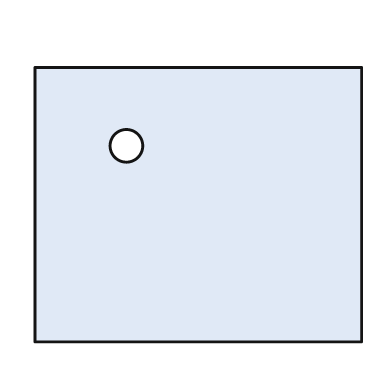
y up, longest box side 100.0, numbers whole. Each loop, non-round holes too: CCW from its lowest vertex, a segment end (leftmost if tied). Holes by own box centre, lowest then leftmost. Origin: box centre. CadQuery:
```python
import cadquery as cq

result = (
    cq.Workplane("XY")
    .moveTo(-50.0, -42.0)
    .lineTo(50.0, -42.0)
    .lineTo(50.0, 42.0)
    .lineTo(-50.0, 42.0)
    .close()
    .moveTo(-22.0, 18.0)
    .circle(5.0)
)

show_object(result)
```